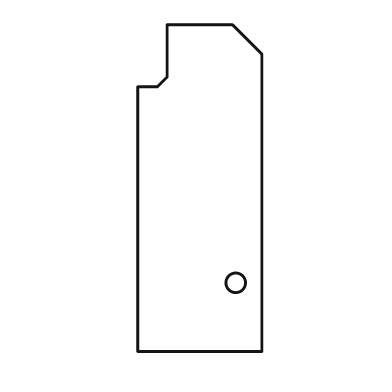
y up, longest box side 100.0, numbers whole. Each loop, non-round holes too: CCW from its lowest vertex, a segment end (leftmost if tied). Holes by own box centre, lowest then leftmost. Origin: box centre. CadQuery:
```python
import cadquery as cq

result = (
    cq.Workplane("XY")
    .moveTo(-19.0, -50.0)
    .lineTo(19.0, -50.0)
    .lineTo(19.0, 41.0)
    .lineTo(10.0, 50.0)
    .lineTo(-10.0, 50.0)
    .lineTo(-10.0, 34.0)
    .lineTo(-13.0, 31.0)
    .lineTo(-19.0, 31.0)
    .close()
    .moveTo(11.0, -29.0)
    .circle(3.0)
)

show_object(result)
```